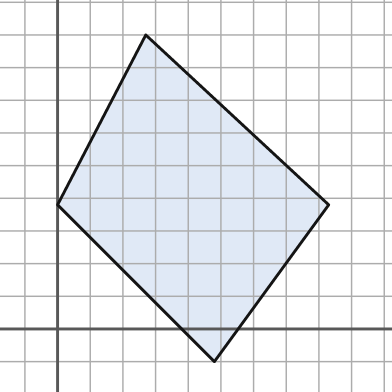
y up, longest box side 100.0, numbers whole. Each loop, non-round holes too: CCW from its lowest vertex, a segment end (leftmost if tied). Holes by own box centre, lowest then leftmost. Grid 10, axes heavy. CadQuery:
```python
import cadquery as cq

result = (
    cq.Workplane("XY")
    .moveTo(48.0, -10.0)
    .lineTo(83.0, 38.0)
    .lineTo(27.0, 90.0)
    .lineTo(0.0, 38.0)
    .close()
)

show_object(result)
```